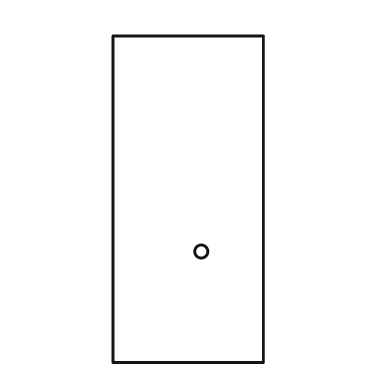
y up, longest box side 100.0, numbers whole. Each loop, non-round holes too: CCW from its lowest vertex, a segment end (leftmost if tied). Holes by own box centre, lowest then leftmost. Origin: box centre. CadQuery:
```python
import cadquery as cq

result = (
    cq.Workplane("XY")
    .moveTo(-23.0, -50.0)
    .lineTo(23.0, -50.0)
    .lineTo(23.0, 50.0)
    .lineTo(-23.0, 50.0)
    .close()
    .moveTo(4.0, -16.0)
    .circle(2.0)
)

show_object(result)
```